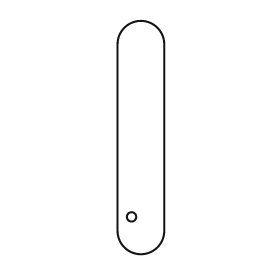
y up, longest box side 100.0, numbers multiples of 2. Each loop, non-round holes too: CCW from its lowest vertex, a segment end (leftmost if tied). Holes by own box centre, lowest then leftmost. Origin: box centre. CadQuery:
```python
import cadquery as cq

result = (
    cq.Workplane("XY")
    .moveTo(-10.0, -40.0)
    .threePointArc((0.0, -50.0), (10.0, -40.0))
    .lineTo(10.0, 40.0)
    .threePointArc((0.0, 50.0), (-10.0, 40.0))
    .close()
    .moveTo(-4.0, -34.0)
    .circle(2.0)
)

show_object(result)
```